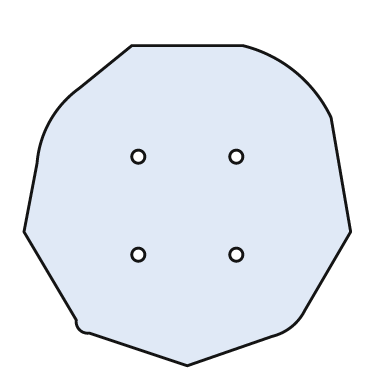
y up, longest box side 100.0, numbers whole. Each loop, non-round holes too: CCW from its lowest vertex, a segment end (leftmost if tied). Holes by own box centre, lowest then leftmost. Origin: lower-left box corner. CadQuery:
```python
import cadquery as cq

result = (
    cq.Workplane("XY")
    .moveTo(50.0, 0.0)
    .lineTo(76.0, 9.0)
    .threePointArc((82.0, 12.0), (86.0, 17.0))
    .lineTo(100.0, 41.0)
    .lineTo(94.0, 76.0)
    .threePointArc((83.0, 90.0), (67.0, 98.0))
    .lineTo(33.0, 98.0)
    .lineTo(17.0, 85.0)
    .threePointArc((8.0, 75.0), (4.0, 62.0))
    .lineTo(0.0, 41.0)
    .lineTo(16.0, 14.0)
    .threePointArc((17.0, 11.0), (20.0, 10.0))
    .close()
    .moveTo(35.0, 34.0)
    .circle(2.0)
    .moveTo(65.0, 34.0)
    .circle(2.0)
    .moveTo(35.0, 64.0)
    .circle(2.0)
    .moveTo(65.0, 64.0)
    .circle(2.0)
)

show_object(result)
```